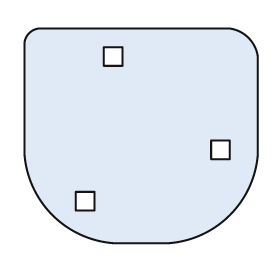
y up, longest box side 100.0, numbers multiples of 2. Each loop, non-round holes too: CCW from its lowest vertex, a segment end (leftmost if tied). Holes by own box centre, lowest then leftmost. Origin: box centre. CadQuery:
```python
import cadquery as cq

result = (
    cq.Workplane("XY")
    .moveTo(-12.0, -46.0)
    .lineTo(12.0, -46.0)
    .threePointArc((38.0, -34.0), (50.0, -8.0))
    .lineTo(50.0, 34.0)
    .threePointArc((46.0, 42.0), (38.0, 46.0))
    .lineTo(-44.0, 46.0)
    .threePointArc((-48.0, 44.0), (-50.0, 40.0))
    .lineTo(-50.0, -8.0)
    .threePointArc((-38.0, -34.0), (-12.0, -46.0))
    .close()
    .moveTo(-28.0, -32.0)
    .lineTo(-20.0, -32.0)
    .lineTo(-20.0, -24.0)
    .lineTo(-28.0, -24.0)
    .close()
    .moveTo(30.0, -10.0)
    .lineTo(38.0, -10.0)
    .lineTo(38.0, -2.0)
    .lineTo(30.0, -2.0)
    .close()
    .moveTo(-16.0, 30.0)
    .lineTo(-8.0, 30.0)
    .lineTo(-8.0, 38.0)
    .lineTo(-16.0, 38.0)
    .close()
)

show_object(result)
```